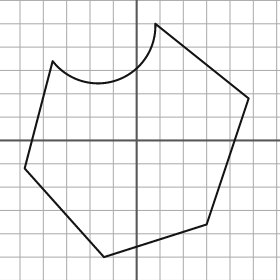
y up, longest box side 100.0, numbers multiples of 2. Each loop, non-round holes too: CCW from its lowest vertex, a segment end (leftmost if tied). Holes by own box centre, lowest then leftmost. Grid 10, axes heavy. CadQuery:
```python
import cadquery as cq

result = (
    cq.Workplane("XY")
    .moveTo(-14.0, -50.0)
    .lineTo(30.0, -36.0)
    .lineTo(48.0, 18.0)
    .lineTo(8.0, 50.0)
    .threePointArc((-8.0, 26.0), (-36.0, 34.0))
    .lineTo(-48.0, -12.0)
    .close()
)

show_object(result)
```